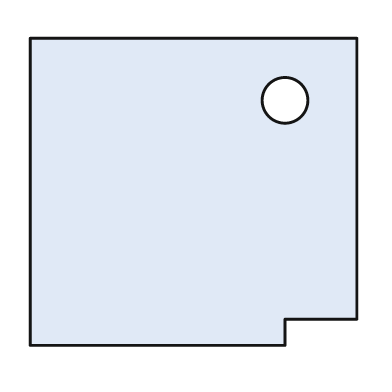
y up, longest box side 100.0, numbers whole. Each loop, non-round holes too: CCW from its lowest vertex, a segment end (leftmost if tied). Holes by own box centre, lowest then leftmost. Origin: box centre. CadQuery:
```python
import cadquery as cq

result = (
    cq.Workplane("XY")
    .moveTo(-50.0, -47.0)
    .lineTo(28.0, -47.0)
    .lineTo(28.0, -39.0)
    .lineTo(50.0, -39.0)
    .lineTo(50.0, 47.0)
    .lineTo(-50.0, 47.0)
    .close()
    .moveTo(28.0, 28.0)
    .circle(7.0)
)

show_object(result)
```